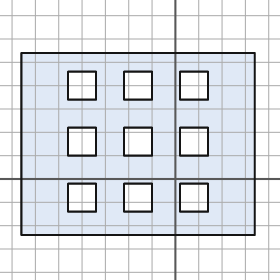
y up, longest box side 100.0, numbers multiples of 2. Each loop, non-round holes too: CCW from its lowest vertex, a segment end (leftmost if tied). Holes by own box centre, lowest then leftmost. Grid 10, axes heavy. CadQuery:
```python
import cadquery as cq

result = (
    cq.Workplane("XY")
    .moveTo(-66.0, -24.0)
    .lineTo(34.0, -24.0)
    .lineTo(34.0, 54.0)
    .lineTo(-66.0, 54.0)
    .close()
    .moveTo(-46.0, -14.0)
    .lineTo(-34.0, -14.0)
    .lineTo(-34.0, -2.0)
    .lineTo(-46.0, -2.0)
    .close()
    .moveTo(-22.0, -14.0)
    .lineTo(-10.0, -14.0)
    .lineTo(-10.0, -2.0)
    .lineTo(-22.0, -2.0)
    .close()
    .moveTo(2.0, -14.0)
    .lineTo(14.0, -14.0)
    .lineTo(14.0, -2.0)
    .lineTo(2.0, -2.0)
    .close()
    .moveTo(-46.0, 10.0)
    .lineTo(-34.0, 10.0)
    .lineTo(-34.0, 22.0)
    .lineTo(-46.0, 22.0)
    .close()
    .moveTo(-22.0, 10.0)
    .lineTo(-10.0, 10.0)
    .lineTo(-10.0, 22.0)
    .lineTo(-22.0, 22.0)
    .close()
    .moveTo(2.0, 10.0)
    .lineTo(14.0, 10.0)
    .lineTo(14.0, 22.0)
    .lineTo(2.0, 22.0)
    .close()
    .moveTo(-46.0, 34.0)
    .lineTo(-34.0, 34.0)
    .lineTo(-34.0, 46.0)
    .lineTo(-46.0, 46.0)
    .close()
    .moveTo(-22.0, 34.0)
    .lineTo(-10.0, 34.0)
    .lineTo(-10.0, 46.0)
    .lineTo(-22.0, 46.0)
    .close()
    .moveTo(2.0, 34.0)
    .lineTo(14.0, 34.0)
    .lineTo(14.0, 46.0)
    .lineTo(2.0, 46.0)
    .close()
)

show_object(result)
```